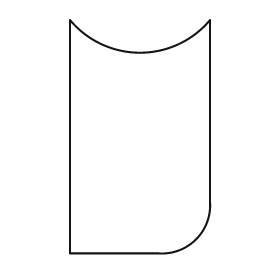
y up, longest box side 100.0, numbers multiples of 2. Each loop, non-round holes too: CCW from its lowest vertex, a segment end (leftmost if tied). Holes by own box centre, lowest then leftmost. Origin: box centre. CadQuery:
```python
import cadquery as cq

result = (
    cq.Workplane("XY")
    .moveTo(-30.0, -50.0)
    .lineTo(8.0, -50.0)
    .threePointArc((24.0, -44.0), (30.0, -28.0))
    .lineTo(30.0, 50.0)
    .threePointArc((0.0, 36.0), (-30.0, 50.0))
    .close()
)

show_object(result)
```